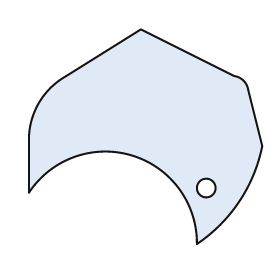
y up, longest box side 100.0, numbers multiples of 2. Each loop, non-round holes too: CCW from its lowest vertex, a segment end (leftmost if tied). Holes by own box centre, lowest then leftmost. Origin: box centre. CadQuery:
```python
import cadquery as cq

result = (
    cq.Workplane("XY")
    .moveTo(22.0, -46.0)
    .threePointArc((40.0, -28.0), (50.0, -4.0))
    .lineTo(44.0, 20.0)
    .threePointArc((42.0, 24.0), (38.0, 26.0))
    .lineTo(-2.0, 46.0)
    .lineTo(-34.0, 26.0)
    .threePointArc((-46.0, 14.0), (-50.0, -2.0))
    .lineTo(-50.0, -24.0)
    .threePointArc((-6.0, -8.0), (22.0, -46.0))
    .close()
    .moveTo(26.0, -22.0)
    .circle(4.0)
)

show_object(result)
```